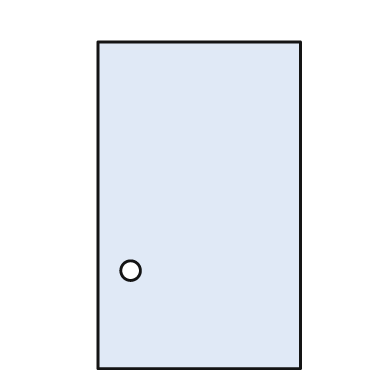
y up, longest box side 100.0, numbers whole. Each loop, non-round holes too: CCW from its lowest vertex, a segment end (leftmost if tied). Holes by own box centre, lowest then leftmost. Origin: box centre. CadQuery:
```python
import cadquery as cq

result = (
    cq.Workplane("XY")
    .moveTo(-31.0, -50.0)
    .lineTo(31.0, -50.0)
    .lineTo(31.0, 50.0)
    .lineTo(-31.0, 50.0)
    .close()
    .moveTo(-21.0, -20.0)
    .circle(3.0)
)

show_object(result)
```